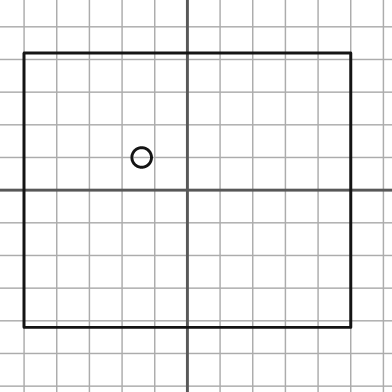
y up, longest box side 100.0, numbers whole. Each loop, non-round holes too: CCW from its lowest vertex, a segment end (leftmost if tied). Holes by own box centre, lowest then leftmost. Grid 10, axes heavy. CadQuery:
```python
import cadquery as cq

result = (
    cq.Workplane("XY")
    .moveTo(-50.0, -42.0)
    .lineTo(50.0, -42.0)
    .lineTo(50.0, 42.0)
    .lineTo(-50.0, 42.0)
    .close()
    .moveTo(-14.0, 10.0)
    .circle(3.0)
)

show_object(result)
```